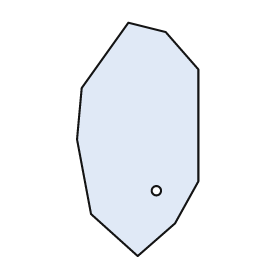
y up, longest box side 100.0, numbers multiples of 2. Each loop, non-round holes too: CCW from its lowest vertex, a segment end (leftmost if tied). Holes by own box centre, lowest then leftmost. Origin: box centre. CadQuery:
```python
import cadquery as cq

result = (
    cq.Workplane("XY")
    .moveTo(0.0, -50.0)
    .lineTo(16.0, -36.0)
    .lineTo(26.0, -18.0)
    .lineTo(26.0, 30.0)
    .lineTo(12.0, 46.0)
    .lineTo(-4.0, 50.0)
    .lineTo(-24.0, 22.0)
    .lineTo(-26.0, 0.0)
    .lineTo(-20.0, -32.0)
    .close()
    .moveTo(8.0, -22.0)
    .circle(2.0)
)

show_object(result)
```